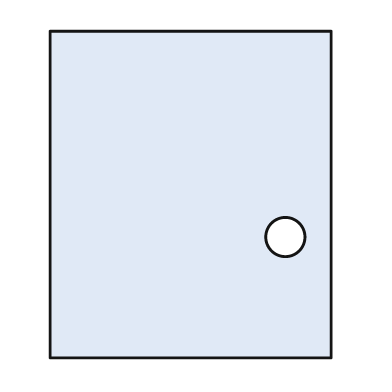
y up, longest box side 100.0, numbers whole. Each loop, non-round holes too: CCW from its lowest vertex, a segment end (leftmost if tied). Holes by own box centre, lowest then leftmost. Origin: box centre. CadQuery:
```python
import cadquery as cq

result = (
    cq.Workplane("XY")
    .moveTo(-43.0, -50.0)
    .lineTo(43.0, -50.0)
    .lineTo(43.0, 50.0)
    .lineTo(-43.0, 50.0)
    .close()
    .moveTo(29.0, -13.0)
    .circle(6.0)
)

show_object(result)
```